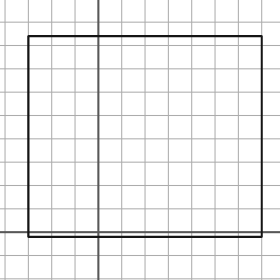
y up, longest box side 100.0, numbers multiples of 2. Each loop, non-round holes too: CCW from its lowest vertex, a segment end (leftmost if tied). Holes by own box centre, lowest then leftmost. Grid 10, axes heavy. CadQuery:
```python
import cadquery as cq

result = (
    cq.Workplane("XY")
    .moveTo(-30.0, -2.0)
    .lineTo(70.0, -2.0)
    .lineTo(70.0, 84.0)
    .lineTo(-30.0, 84.0)
    .close()
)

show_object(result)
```